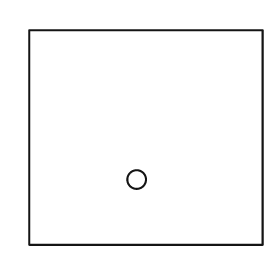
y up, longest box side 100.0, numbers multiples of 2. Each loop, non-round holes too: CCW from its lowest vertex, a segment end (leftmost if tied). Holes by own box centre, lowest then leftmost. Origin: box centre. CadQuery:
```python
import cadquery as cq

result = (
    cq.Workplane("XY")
    .moveTo(-50.0, -46.0)
    .lineTo(50.0, -46.0)
    .lineTo(50.0, 46.0)
    .lineTo(-50.0, 46.0)
    .close()
    .moveTo(-4.0, -18.0)
    .circle(4.0)
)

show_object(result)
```